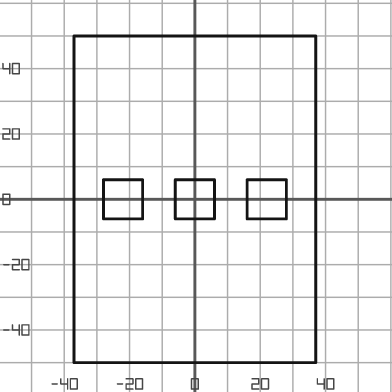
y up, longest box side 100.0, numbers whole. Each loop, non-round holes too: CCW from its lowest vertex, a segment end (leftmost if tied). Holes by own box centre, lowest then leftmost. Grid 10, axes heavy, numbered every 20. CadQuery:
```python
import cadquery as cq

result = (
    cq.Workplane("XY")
    .moveTo(-37.0, -50.0)
    .lineTo(37.0, -50.0)
    .lineTo(37.0, 50.0)
    .lineTo(-37.0, 50.0)
    .close()
    .moveTo(-28.0, -6.0)
    .lineTo(-16.0, -6.0)
    .lineTo(-16.0, 6.0)
    .lineTo(-28.0, 6.0)
    .close()
    .moveTo(-6.0, -6.0)
    .lineTo(6.0, -6.0)
    .lineTo(6.0, 6.0)
    .lineTo(-6.0, 6.0)
    .close()
    .moveTo(16.0, -6.0)
    .lineTo(28.0, -6.0)
    .lineTo(28.0, 6.0)
    .lineTo(16.0, 6.0)
    .close()
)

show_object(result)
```